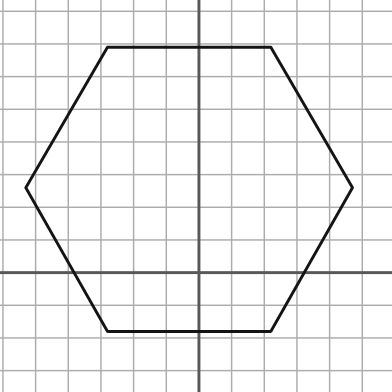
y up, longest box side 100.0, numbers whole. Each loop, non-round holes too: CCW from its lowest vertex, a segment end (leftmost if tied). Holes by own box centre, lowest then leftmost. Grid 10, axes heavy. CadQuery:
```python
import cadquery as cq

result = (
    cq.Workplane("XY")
    .moveTo(-28.0, -18.0)
    .lineTo(22.0, -18.0)
    .lineTo(47.0, 26.0)
    .lineTo(22.0, 69.0)
    .lineTo(-28.0, 69.0)
    .lineTo(-53.0, 26.0)
    .close()
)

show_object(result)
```